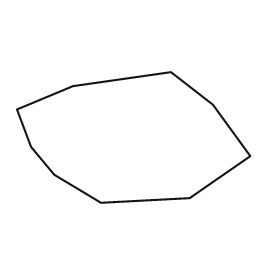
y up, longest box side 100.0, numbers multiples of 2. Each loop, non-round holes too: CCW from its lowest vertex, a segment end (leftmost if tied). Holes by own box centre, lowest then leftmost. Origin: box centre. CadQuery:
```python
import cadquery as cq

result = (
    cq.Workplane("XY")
    .moveTo(-14.0, -28.0)
    .lineTo(24.0, -26.0)
    .lineTo(50.0, -8.0)
    .lineTo(34.0, 14.0)
    .lineTo(16.0, 28.0)
    .lineTo(-26.0, 22.0)
    .lineTo(-50.0, 12.0)
    .lineTo(-44.0, -4.0)
    .lineTo(-34.0, -16.0)
    .close()
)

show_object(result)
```